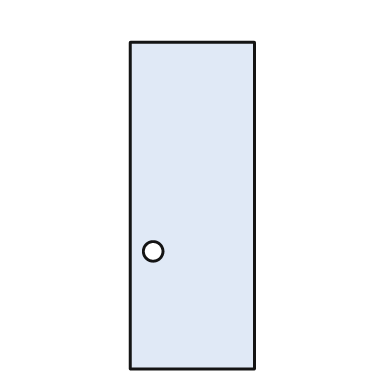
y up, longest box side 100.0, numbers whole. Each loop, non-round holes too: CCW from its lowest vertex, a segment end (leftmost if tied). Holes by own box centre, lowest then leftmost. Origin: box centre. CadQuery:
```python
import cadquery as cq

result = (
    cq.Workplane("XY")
    .moveTo(-19.0, -50.0)
    .lineTo(19.0, -50.0)
    .lineTo(19.0, 50.0)
    .lineTo(-19.0, 50.0)
    .close()
    .moveTo(-12.0, -14.0)
    .circle(3.0)
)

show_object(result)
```